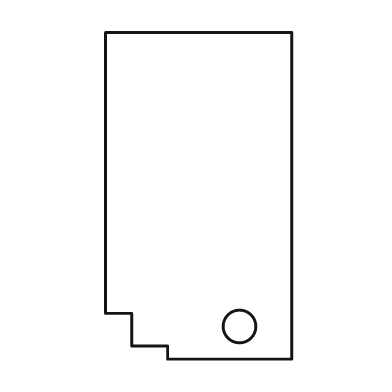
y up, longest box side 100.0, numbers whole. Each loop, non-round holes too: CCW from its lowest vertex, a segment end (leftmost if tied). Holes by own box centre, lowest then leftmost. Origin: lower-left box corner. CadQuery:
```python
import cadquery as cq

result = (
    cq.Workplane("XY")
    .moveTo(19.0, 0.0)
    .lineTo(57.0, 0.0)
    .lineTo(57.0, 100.0)
    .lineTo(0.0, 100.0)
    .lineTo(0.0, 14.0)
    .lineTo(8.0, 14.0)
    .lineTo(8.0, 4.0)
    .lineTo(19.0, 4.0)
    .close()
    .moveTo(41.0, 10.0)
    .circle(5.0)
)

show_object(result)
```